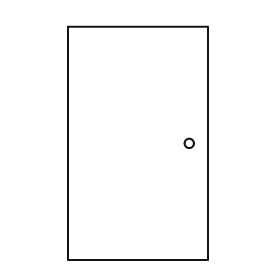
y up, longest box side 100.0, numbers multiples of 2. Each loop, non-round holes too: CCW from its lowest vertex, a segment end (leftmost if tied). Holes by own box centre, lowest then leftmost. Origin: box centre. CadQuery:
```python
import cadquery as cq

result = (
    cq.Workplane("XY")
    .moveTo(-30.0, -50.0)
    .lineTo(30.0, -50.0)
    .lineTo(30.0, 50.0)
    .lineTo(-30.0, 50.0)
    .close()
    .moveTo(22.0, 0.0)
    .circle(2.0)
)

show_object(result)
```